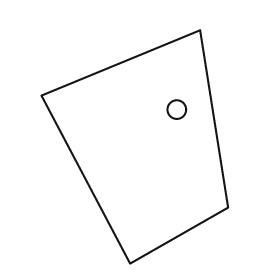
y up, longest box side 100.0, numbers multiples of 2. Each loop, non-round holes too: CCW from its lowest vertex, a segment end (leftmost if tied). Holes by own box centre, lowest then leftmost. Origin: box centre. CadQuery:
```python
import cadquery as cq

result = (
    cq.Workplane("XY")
    .moveTo(-2.0, -50.0)
    .lineTo(40.0, -26.0)
    .lineTo(28.0, 50.0)
    .lineTo(-40.0, 22.0)
    .close()
    .moveTo(18.0, 16.0)
    .circle(4.0)
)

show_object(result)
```